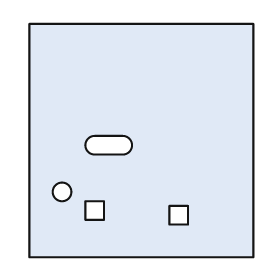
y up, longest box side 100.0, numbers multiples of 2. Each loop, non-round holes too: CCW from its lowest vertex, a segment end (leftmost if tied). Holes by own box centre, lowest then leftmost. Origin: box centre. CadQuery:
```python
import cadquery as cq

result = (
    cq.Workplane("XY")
    .moveTo(-48.0, -50.0)
    .lineTo(48.0, -50.0)
    .lineTo(48.0, 50.0)
    .lineTo(-48.0, 50.0)
    .close()
    .moveTo(12.0, -36.0)
    .lineTo(20.0, -36.0)
    .lineTo(20.0, -28.0)
    .lineTo(12.0, -28.0)
    .close()
    .moveTo(-24.0, -34.0)
    .lineTo(-16.0, -34.0)
    .lineTo(-16.0, -26.0)
    .lineTo(-24.0, -26.0)
    .close()
    .moveTo(-34.0, -22.0)
    .circle(4.0)
    .moveTo(-20.0, -6.0)
    .lineTo(-8.0, -6.0)
    .threePointArc((-4.0, -2.0), (-8.0, 2.0))
    .lineTo(-20.0, 2.0)
    .threePointArc((-24.0, -2.0), (-20.0, -6.0))
    .close()
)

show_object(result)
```